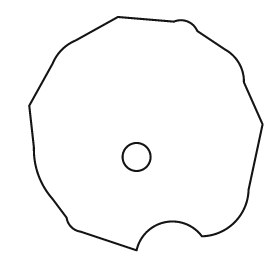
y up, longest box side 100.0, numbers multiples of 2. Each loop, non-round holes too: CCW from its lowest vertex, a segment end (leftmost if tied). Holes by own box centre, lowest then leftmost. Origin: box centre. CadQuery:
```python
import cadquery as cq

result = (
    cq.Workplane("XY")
    .moveTo(-4.0, -50.0)
    .threePointArc((8.0, -38.0), (24.0, -44.0))
    .threePointArc((38.0, -38.0), (44.0, -24.0))
    .lineTo(50.0, 4.0)
    .lineTo(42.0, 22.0)
    .threePointArc((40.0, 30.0), (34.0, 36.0))
    .lineTo(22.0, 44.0)
    .threePointArc((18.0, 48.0), (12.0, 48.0))
    .lineTo(-12.0, 50.0)
    .lineTo(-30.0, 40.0)
    .threePointArc((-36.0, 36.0), (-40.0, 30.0))
    .lineTo(-50.0, 12.0)
    .lineTo(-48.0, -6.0)
    .threePointArc((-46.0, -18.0), (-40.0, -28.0))
    .lineTo(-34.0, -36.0)
    .threePointArc((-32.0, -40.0), (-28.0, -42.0))
    .close()
    .moveTo(-4.0, -10.0)
    .circle(6.0)
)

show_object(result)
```